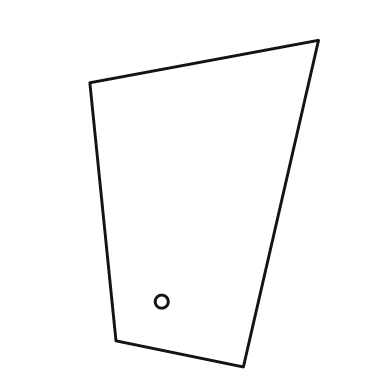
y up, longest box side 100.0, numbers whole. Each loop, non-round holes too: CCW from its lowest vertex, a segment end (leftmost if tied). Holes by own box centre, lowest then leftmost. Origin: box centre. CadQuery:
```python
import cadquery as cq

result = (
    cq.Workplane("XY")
    .moveTo(12.0, -50.0)
    .lineTo(35.0, 50.0)
    .lineTo(-35.0, 37.0)
    .lineTo(-27.0, -42.0)
    .close()
    .moveTo(-13.0, -30.0)
    .circle(2.0)
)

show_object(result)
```